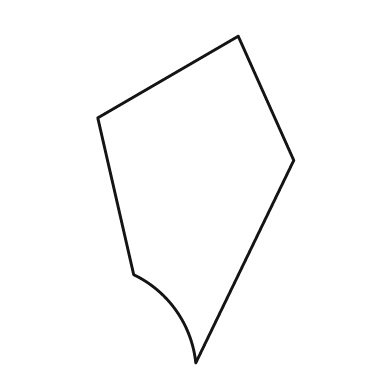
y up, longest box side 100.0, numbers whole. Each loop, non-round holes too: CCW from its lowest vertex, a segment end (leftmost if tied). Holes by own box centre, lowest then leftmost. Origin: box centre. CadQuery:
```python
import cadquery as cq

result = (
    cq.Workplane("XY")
    .moveTo(0.0, -50.0)
    .lineTo(30.0, 12.0)
    .lineTo(13.0, 50.0)
    .lineTo(-30.0, 25.0)
    .lineTo(-19.0, -23.0)
    .threePointArc((-6.0, -34.0), (0.0, -50.0))
    .close()
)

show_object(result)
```